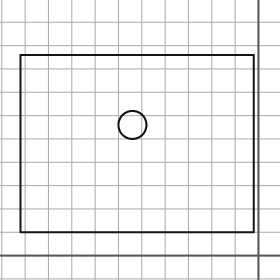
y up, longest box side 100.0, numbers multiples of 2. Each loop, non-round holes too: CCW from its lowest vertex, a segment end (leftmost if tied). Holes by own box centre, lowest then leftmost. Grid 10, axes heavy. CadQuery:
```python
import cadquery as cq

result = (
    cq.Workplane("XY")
    .moveTo(-102.0, 10.0)
    .lineTo(-2.0, 10.0)
    .lineTo(-2.0, 86.0)
    .lineTo(-102.0, 86.0)
    .close()
    .moveTo(-54.0, 56.0)
    .circle(6.0)
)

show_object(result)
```